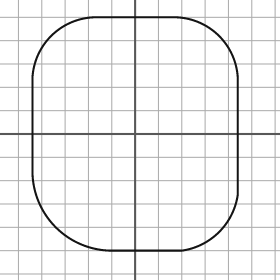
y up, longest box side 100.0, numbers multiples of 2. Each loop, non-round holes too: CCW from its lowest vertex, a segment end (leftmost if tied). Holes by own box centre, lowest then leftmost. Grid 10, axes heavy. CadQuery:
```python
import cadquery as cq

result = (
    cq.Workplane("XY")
    .moveTo(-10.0, -50.0)
    .lineTo(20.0, -50.0)
    .threePointArc((36.0, -42.0), (44.0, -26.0))
    .lineTo(44.0, 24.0)
    .threePointArc((36.0, 42.0), (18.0, 50.0))
    .lineTo(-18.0, 50.0)
    .threePointArc((-36.0, 42.0), (-44.0, 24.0))
    .lineTo(-44.0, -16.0)
    .threePointArc((-34.0, -40.0), (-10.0, -50.0))
    .close()
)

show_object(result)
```